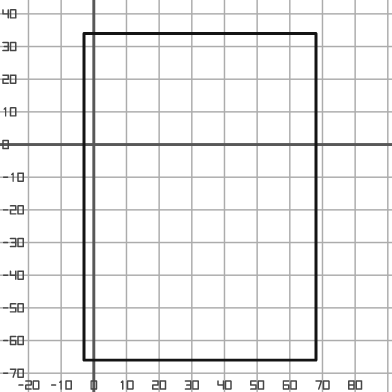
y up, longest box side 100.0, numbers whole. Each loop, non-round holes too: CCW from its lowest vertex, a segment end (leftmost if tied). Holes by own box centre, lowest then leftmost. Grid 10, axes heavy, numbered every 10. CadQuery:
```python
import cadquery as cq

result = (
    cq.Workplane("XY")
    .moveTo(-3.0, -66.0)
    .lineTo(68.0, -66.0)
    .lineTo(68.0, 34.0)
    .lineTo(-3.0, 34.0)
    .close()
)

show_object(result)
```